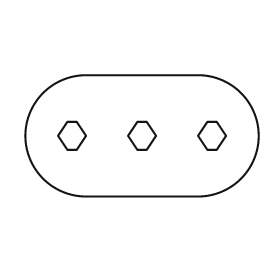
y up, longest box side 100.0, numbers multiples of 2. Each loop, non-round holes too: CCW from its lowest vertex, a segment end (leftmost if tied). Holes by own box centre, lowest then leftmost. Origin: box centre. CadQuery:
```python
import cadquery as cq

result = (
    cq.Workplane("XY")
    .moveTo(-24.0, -26.0)
    .lineTo(24.0, -26.0)
    .threePointArc((50.0, 0.0), (24.0, 26.0))
    .lineTo(-24.0, 26.0)
    .threePointArc((-50.0, 0.0), (-24.0, -26.0))
    .close()
    .moveTo(-32.0, -6.0)
    .lineTo(-28.0, -6.0)
    .lineTo(-24.0, 0.0)
    .lineTo(-28.0, 6.0)
    .lineTo(-32.0, 6.0)
    .lineTo(-36.0, 0.0)
    .close()
    .moveTo(-2.0, -6.0)
    .lineTo(2.0, -6.0)
    .lineTo(6.0, 0.0)
    .lineTo(2.0, 6.0)
    .lineTo(-2.0, 6.0)
    .lineTo(-6.0, 0.0)
    .close()
    .moveTo(28.0, -6.0)
    .lineTo(32.0, -6.0)
    .lineTo(36.0, 0.0)
    .lineTo(32.0, 6.0)
    .lineTo(28.0, 6.0)
    .lineTo(24.0, 0.0)
    .close()
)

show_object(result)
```